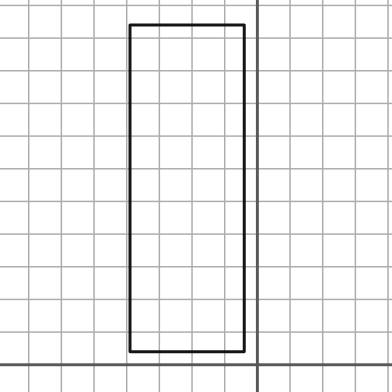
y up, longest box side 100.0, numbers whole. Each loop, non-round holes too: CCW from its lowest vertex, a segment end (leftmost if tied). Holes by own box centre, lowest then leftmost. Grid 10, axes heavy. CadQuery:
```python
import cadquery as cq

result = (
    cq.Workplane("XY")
    .moveTo(-39.0, 4.0)
    .lineTo(-4.0, 4.0)
    .lineTo(-4.0, 104.0)
    .lineTo(-39.0, 104.0)
    .close()
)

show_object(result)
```